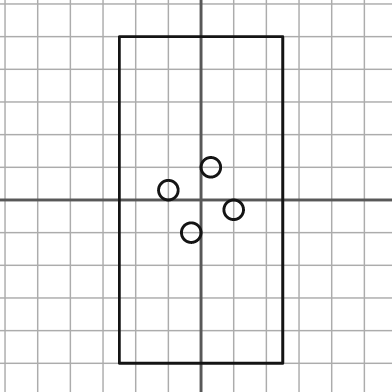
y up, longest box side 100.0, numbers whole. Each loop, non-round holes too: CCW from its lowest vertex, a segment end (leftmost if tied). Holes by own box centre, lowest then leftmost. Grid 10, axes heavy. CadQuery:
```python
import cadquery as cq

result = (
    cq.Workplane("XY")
    .moveTo(-25.0, -50.0)
    .lineTo(25.0, -50.0)
    .lineTo(25.0, 50.0)
    .lineTo(-25.0, 50.0)
    .close()
    .moveTo(-3.0, -10.0)
    .circle(3.0)
    .moveTo(10.0, -3.0)
    .circle(3.0)
    .moveTo(-10.0, 3.0)
    .circle(3.0)
    .moveTo(3.0, 10.0)
    .circle(3.0)
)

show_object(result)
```